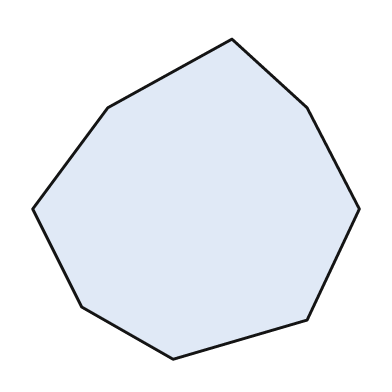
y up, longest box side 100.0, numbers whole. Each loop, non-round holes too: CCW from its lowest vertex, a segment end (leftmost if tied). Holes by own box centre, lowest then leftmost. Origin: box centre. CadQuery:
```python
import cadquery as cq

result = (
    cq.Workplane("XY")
    .moveTo(-7.0, -49.0)
    .lineTo(34.0, -37.0)
    .lineTo(50.0, -3.0)
    .lineTo(34.0, 28.0)
    .lineTo(11.0, 49.0)
    .lineTo(-27.0, 28.0)
    .lineTo(-50.0, -3.0)
    .lineTo(-35.0, -33.0)
    .close()
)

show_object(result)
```